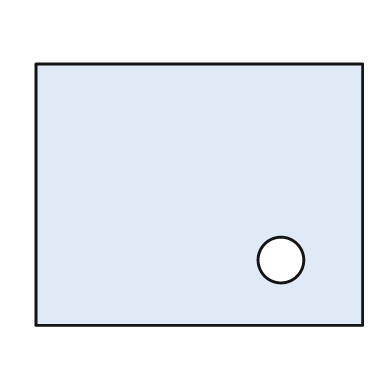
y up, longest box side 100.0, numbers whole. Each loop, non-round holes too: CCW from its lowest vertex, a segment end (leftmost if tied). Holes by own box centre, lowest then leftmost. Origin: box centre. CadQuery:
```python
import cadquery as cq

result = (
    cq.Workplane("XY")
    .moveTo(-50.0, -40.0)
    .lineTo(50.0, -40.0)
    .lineTo(50.0, 40.0)
    .lineTo(-50.0, 40.0)
    .close()
    .moveTo(25.0, -20.0)
    .circle(7.0)
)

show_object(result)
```